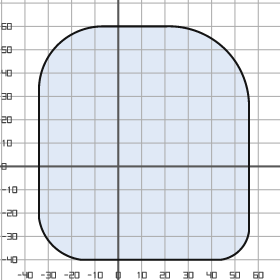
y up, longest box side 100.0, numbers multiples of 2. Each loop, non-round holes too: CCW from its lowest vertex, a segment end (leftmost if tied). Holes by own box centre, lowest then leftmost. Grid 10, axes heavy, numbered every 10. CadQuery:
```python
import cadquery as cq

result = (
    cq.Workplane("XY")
    .moveTo(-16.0, -40.0)
    .lineTo(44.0, -40.0)
    .threePointArc((52.0, -36.0), (56.0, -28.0))
    .lineTo(56.0, 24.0)
    .threePointArc((46.0, 50.0), (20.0, 60.0))
    .lineTo(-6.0, 60.0)
    .threePointArc((-26.0, 52.0), (-34.0, 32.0))
    .lineTo(-34.0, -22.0)
    .threePointArc((-28.0, -34.0), (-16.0, -40.0))
    .close()
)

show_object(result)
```